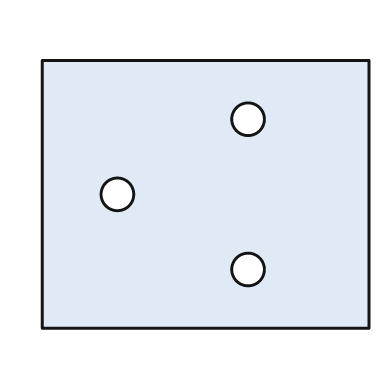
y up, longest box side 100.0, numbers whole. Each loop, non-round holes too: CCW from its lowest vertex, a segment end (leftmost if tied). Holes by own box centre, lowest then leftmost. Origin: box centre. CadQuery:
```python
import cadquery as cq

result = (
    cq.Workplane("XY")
    .moveTo(-50.0, -41.0)
    .lineTo(50.0, -41.0)
    .lineTo(50.0, 41.0)
    .lineTo(-50.0, 41.0)
    .close()
    .moveTo(13.0, -23.0)
    .circle(5.0)
    .moveTo(-27.0, 0.0)
    .circle(5.0)
    .moveTo(13.0, 23.0)
    .circle(5.0)
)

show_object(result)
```